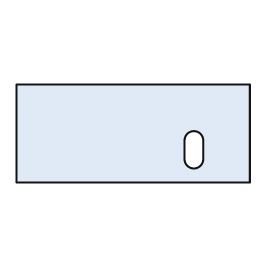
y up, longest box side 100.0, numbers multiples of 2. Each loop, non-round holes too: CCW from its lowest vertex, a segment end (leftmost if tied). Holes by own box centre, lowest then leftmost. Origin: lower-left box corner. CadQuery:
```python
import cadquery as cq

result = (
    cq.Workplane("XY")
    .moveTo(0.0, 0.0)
    .lineTo(100.0, 0.0)
    .lineTo(100.0, 42.0)
    .lineTo(0.0, 42.0)
    .close()
    .moveTo(72.0, 10.0)
    .threePointArc((76.0, 6.0), (80.0, 10.0))
    .lineTo(80.0, 18.0)
    .threePointArc((76.0, 22.0), (72.0, 18.0))
    .close()
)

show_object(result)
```